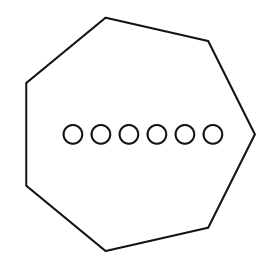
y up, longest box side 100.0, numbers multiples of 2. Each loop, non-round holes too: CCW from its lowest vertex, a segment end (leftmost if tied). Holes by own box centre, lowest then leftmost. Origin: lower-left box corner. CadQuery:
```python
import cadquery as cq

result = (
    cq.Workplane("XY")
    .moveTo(34.0, 0.0)
    .lineTo(78.0, 10.0)
    .lineTo(98.0, 50.0)
    .lineTo(78.0, 90.0)
    .lineTo(34.0, 100.0)
    .lineTo(0.0, 72.0)
    .lineTo(0.0, 28.0)
    .close()
    .moveTo(20.0, 50.0)
    .circle(4.0)
    .moveTo(32.0, 50.0)
    .circle(4.0)
    .moveTo(44.0, 50.0)
    .circle(4.0)
    .moveTo(56.0, 50.0)
    .circle(4.0)
    .moveTo(68.0, 50.0)
    .circle(4.0)
    .moveTo(80.0, 50.0)
    .circle(4.0)
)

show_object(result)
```